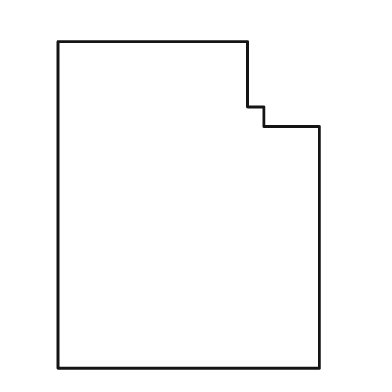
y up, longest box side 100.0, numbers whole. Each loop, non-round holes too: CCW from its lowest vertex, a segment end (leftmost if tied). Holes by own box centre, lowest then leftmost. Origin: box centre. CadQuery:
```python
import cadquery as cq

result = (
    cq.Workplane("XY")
    .moveTo(-40.0, -50.0)
    .lineTo(40.0, -50.0)
    .lineTo(40.0, 24.0)
    .lineTo(23.0, 24.0)
    .lineTo(23.0, 30.0)
    .lineTo(18.0, 30.0)
    .lineTo(18.0, 50.0)
    .lineTo(-40.0, 50.0)
    .close()
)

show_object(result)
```